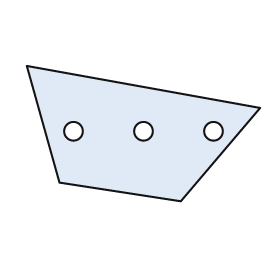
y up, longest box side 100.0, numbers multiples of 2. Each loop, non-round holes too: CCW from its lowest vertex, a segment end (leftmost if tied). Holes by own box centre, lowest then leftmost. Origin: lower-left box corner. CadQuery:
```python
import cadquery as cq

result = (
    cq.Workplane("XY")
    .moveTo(66.0, 0.0)
    .lineTo(100.0, 40.0)
    .lineTo(0.0, 58.0)
    .lineTo(14.0, 8.0)
    .close()
    .moveTo(20.0, 30.0)
    .circle(4.0)
    .moveTo(50.0, 30.0)
    .circle(4.0)
    .moveTo(80.0, 30.0)
    .circle(4.0)
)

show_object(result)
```